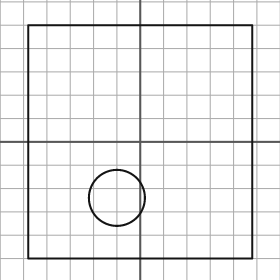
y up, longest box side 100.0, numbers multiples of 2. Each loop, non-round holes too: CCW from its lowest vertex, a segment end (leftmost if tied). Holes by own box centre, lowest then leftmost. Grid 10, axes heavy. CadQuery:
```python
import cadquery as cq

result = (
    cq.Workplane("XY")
    .moveTo(-48.0, -50.0)
    .lineTo(48.0, -50.0)
    .lineTo(48.0, 50.0)
    .lineTo(-48.0, 50.0)
    .close()
    .moveTo(-10.0, -24.0)
    .circle(12.0)
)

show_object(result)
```